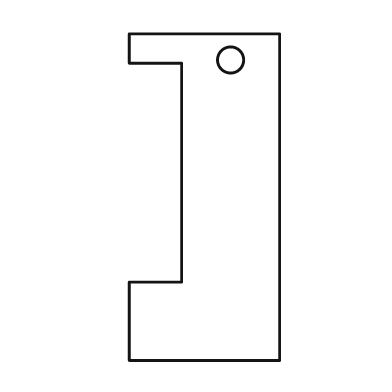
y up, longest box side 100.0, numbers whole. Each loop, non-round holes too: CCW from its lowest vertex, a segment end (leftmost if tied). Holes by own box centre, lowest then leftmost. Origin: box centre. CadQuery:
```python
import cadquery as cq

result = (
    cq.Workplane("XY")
    .moveTo(-23.0, -50.0)
    .lineTo(23.0, -50.0)
    .lineTo(23.0, 50.0)
    .lineTo(-23.0, 50.0)
    .lineTo(-23.0, 41.0)
    .lineTo(-7.0, 41.0)
    .lineTo(-7.0, -26.0)
    .lineTo(-23.0, -26.0)
    .close()
    .moveTo(8.0, 42.0)
    .circle(4.0)
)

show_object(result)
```